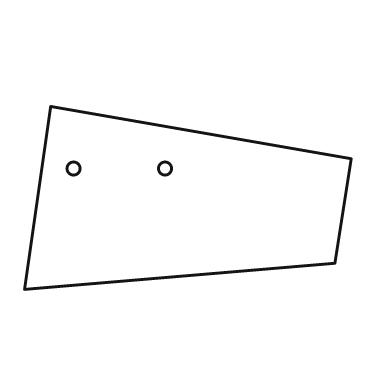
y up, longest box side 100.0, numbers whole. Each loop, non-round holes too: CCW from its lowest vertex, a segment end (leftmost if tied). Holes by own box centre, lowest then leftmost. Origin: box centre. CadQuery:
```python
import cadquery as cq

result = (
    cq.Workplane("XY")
    .moveTo(-50.0, -28.0)
    .lineTo(45.0, -20.0)
    .lineTo(50.0, 12.0)
    .lineTo(-42.0, 28.0)
    .close()
    .moveTo(-35.0, 9.0)
    .circle(2.0)
    .moveTo(-7.0, 9.0)
    .circle(2.0)
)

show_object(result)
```